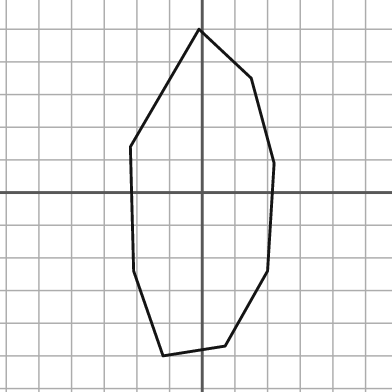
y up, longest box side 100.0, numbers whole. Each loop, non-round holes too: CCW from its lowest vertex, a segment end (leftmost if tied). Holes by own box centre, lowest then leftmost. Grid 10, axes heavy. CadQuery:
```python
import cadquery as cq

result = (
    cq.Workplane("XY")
    .moveTo(-12.0, -50.0)
    .lineTo(7.0, -47.0)
    .lineTo(20.0, -24.0)
    .lineTo(22.0, 9.0)
    .lineTo(15.0, 35.0)
    .lineTo(-1.0, 50.0)
    .lineTo(-22.0, 14.0)
    .lineTo(-21.0, -24.0)
    .close()
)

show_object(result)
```